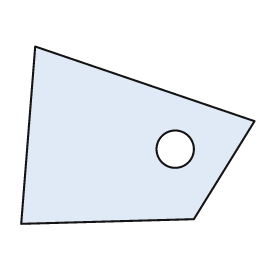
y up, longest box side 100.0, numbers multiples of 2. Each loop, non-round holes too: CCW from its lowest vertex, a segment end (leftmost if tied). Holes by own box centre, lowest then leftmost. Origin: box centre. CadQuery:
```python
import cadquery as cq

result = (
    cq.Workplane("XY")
    .moveTo(-50.0, -38.0)
    .lineTo(24.0, -36.0)
    .lineTo(50.0, 6.0)
    .lineTo(-44.0, 38.0)
    .close()
    .moveTo(16.0, -6.0)
    .circle(8.0)
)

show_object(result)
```